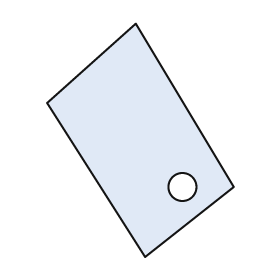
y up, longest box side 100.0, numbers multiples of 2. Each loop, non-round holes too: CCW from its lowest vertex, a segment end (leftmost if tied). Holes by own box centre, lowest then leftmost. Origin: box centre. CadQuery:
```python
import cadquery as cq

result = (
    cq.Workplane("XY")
    .moveTo(2.0, -50.0)
    .lineTo(40.0, -20.0)
    .lineTo(-2.0, 50.0)
    .lineTo(-40.0, 16.0)
    .close()
    .moveTo(18.0, -20.0)
    .circle(6.0)
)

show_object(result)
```